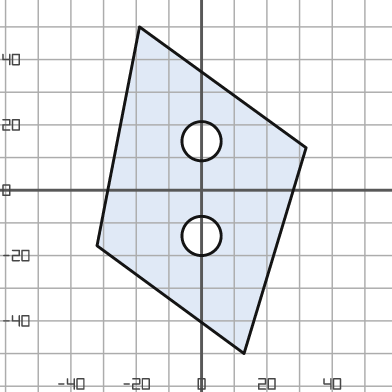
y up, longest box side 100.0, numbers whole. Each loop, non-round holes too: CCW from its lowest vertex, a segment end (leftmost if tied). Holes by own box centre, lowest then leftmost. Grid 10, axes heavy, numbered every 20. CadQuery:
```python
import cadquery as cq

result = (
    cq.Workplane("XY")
    .moveTo(13.0, -50.0)
    .lineTo(32.0, 13.0)
    .lineTo(-19.0, 50.0)
    .lineTo(-32.0, -17.0)
    .close()
    .moveTo(0.0, -14.0)
    .circle(6.0)
    .moveTo(0.0, 15.0)
    .circle(6.0)
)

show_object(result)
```